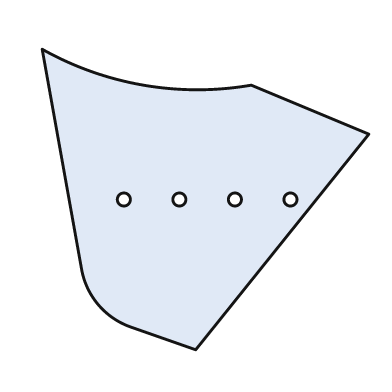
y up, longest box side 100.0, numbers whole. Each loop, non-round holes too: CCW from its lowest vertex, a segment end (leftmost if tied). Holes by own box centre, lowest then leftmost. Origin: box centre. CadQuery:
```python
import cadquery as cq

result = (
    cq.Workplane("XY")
    .moveTo(-3.0, -46.0)
    .lineTo(50.0, 20.0)
    .lineTo(14.0, 35.0)
    .threePointArc((-19.0, 35.0), (-50.0, 46.0))
    .lineTo(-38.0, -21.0)
    .threePointArc((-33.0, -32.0), (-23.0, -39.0))
    .close()
    .moveTo(-25.0, 0.0)
    .circle(2.0)
    .moveTo(-8.0, 0.0)
    .circle(2.0)
    .moveTo(9.0, 0.0)
    .circle(2.0)
    .moveTo(26.0, 0.0)
    .circle(2.0)
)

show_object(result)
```